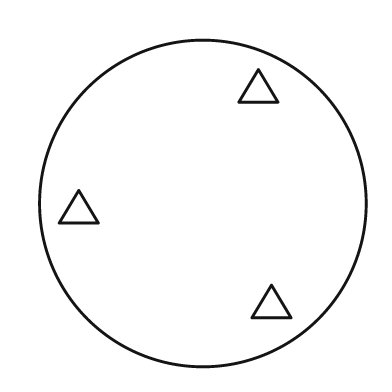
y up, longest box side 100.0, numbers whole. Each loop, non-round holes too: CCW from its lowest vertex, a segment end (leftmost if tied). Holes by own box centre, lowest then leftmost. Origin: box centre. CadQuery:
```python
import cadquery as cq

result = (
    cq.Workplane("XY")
    .moveTo(0.0, 0.0)
    .circle(50.0)
    .moveTo(15.0, -35.0)
    .lineTo(27.0, -35.0)
    .lineTo(21.0, -25.0)
    .close()
    .moveTo(-44.0, -6.0)
    .lineTo(-32.0, -6.0)
    .lineTo(-38.0, 4.0)
    .close()
    .moveTo(11.0, 31.0)
    .lineTo(23.0, 31.0)
    .lineTo(17.0, 41.0)
    .close()
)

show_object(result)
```